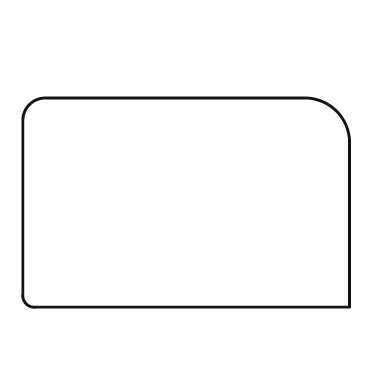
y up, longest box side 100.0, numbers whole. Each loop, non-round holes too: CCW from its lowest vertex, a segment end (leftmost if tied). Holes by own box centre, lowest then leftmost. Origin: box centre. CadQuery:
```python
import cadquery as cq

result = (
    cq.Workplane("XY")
    .moveTo(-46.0, -32.0)
    .lineTo(50.0, -32.0)
    .lineTo(50.0, 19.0)
    .threePointArc((46.0, 28.0), (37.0, 32.0))
    .lineTo(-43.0, 32.0)
    .threePointArc((-48.0, 30.0), (-50.0, 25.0))
    .lineTo(-50.0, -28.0)
    .threePointArc((-49.0, -31.0), (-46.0, -32.0))
    .close()
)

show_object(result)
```